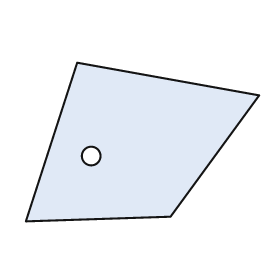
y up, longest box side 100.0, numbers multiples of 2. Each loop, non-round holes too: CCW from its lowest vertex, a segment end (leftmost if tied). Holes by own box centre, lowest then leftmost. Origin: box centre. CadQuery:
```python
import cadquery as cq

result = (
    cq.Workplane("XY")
    .moveTo(-50.0, -34.0)
    .lineTo(12.0, -32.0)
    .lineTo(50.0, 20.0)
    .lineTo(-28.0, 34.0)
    .close()
    .moveTo(-22.0, -6.0)
    .circle(4.0)
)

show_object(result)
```